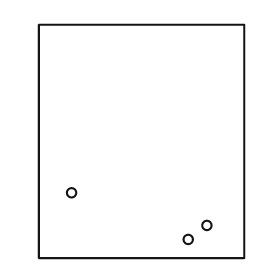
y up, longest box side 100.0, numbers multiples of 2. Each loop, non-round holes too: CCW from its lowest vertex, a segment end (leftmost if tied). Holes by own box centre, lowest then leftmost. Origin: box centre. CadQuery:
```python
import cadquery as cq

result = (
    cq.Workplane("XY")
    .moveTo(-44.0, -50.0)
    .lineTo(44.0, -50.0)
    .lineTo(44.0, 50.0)
    .lineTo(-44.0, 50.0)
    .close()
    .moveTo(20.0, -42.0)
    .circle(2.0)
    .moveTo(28.0, -36.0)
    .circle(2.0)
    .moveTo(-30.0, -22.0)
    .circle(2.0)
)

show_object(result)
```